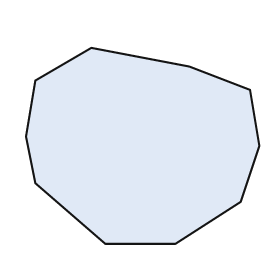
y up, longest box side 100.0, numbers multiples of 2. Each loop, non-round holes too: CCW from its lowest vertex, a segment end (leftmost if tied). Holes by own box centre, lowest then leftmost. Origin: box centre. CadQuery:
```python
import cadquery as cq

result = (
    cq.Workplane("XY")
    .moveTo(-16.0, -42.0)
    .lineTo(14.0, -42.0)
    .lineTo(42.0, -24.0)
    .lineTo(50.0, 0.0)
    .lineTo(46.0, 24.0)
    .lineTo(20.0, 34.0)
    .lineTo(-22.0, 42.0)
    .lineTo(-46.0, 28.0)
    .lineTo(-50.0, 4.0)
    .lineTo(-46.0, -16.0)
    .close()
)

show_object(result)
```